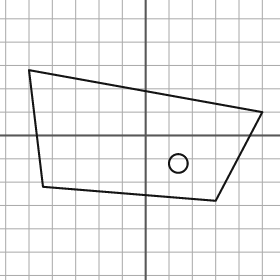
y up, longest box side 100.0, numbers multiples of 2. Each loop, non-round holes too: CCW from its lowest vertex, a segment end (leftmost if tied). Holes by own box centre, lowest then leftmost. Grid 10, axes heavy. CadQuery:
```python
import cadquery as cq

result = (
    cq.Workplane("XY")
    .moveTo(30.0, -28.0)
    .lineTo(50.0, 10.0)
    .lineTo(-50.0, 28.0)
    .lineTo(-44.0, -22.0)
    .close()
    .moveTo(14.0, -12.0)
    .circle(4.0)
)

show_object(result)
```